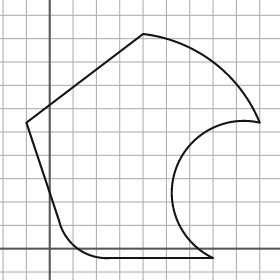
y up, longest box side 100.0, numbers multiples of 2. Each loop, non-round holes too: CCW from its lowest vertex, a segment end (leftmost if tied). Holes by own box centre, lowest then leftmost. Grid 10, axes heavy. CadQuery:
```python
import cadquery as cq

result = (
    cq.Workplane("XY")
    .moveTo(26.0, -4.0)
    .lineTo(70.0, -4.0)
    .threePointArc((54.0, 34.0), (90.0, 54.0))
    .threePointArc((70.0, 80.0), (40.0, 92.0))
    .lineTo(-10.0, 54.0)
    .lineTo(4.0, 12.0)
    .threePointArc((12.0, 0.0), (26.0, -4.0))
    .close()
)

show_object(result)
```